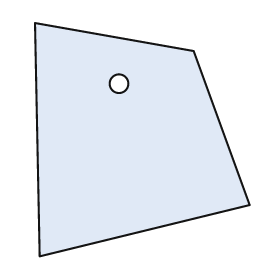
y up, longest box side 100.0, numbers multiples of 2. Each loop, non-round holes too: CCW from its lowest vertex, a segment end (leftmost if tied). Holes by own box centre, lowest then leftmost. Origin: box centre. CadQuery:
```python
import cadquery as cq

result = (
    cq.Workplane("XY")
    .moveTo(-44.0, -50.0)
    .lineTo(46.0, -28.0)
    .lineTo(22.0, 38.0)
    .lineTo(-46.0, 50.0)
    .close()
    .moveTo(-10.0, 24.0)
    .circle(4.0)
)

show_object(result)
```